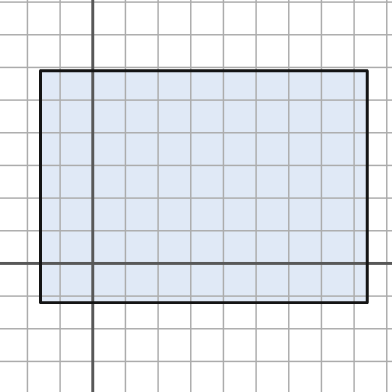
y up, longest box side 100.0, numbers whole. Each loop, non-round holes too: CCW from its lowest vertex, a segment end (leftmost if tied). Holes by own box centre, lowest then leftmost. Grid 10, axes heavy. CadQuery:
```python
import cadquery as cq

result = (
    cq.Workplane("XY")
    .moveTo(-16.0, -12.0)
    .lineTo(84.0, -12.0)
    .lineTo(84.0, 59.0)
    .lineTo(-16.0, 59.0)
    .close()
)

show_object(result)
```